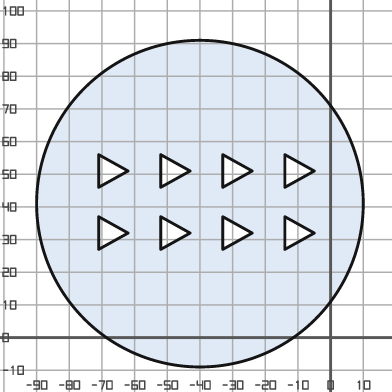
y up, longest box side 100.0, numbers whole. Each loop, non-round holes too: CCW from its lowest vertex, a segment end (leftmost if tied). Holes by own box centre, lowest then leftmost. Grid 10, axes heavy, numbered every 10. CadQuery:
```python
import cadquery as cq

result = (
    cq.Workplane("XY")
    .moveTo(-40.0, 41.0)
    .circle(50.0)
    .moveTo(-71.0, 27.0)
    .lineTo(-62.0, 32.0)
    .lineTo(-71.0, 37.0)
    .close()
    .moveTo(-52.0, 27.0)
    .lineTo(-43.0, 32.0)
    .lineTo(-52.0, 37.0)
    .close()
    .moveTo(-33.0, 27.0)
    .lineTo(-24.0, 32.0)
    .lineTo(-33.0, 37.0)
    .close()
    .moveTo(-14.0, 27.0)
    .lineTo(-5.0, 32.0)
    .lineTo(-14.0, 37.0)
    .close()
    .moveTo(-71.0, 46.0)
    .lineTo(-62.0, 51.0)
    .lineTo(-71.0, 56.0)
    .close()
    .moveTo(-52.0, 46.0)
    .lineTo(-43.0, 51.0)
    .lineTo(-52.0, 56.0)
    .close()
    .moveTo(-33.0, 46.0)
    .lineTo(-24.0, 51.0)
    .lineTo(-33.0, 56.0)
    .close()
    .moveTo(-14.0, 46.0)
    .lineTo(-5.0, 51.0)
    .lineTo(-14.0, 56.0)
    .close()
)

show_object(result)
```